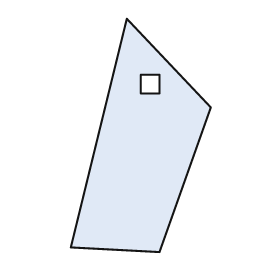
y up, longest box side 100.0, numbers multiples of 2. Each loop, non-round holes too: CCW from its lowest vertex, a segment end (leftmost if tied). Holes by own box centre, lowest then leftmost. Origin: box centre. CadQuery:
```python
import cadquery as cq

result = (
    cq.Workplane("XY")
    .moveTo(8.0, -50.0)
    .lineTo(30.0, 12.0)
    .lineTo(-6.0, 50.0)
    .lineTo(-30.0, -48.0)
    .close()
    .moveTo(0.0, 18.0)
    .lineTo(8.0, 18.0)
    .lineTo(8.0, 26.0)
    .lineTo(0.0, 26.0)
    .close()
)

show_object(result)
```